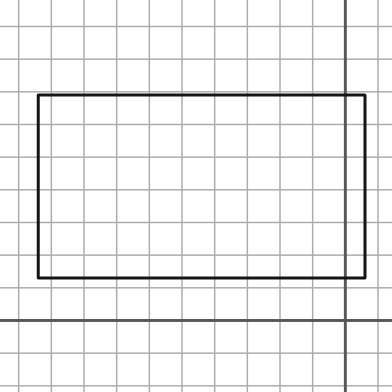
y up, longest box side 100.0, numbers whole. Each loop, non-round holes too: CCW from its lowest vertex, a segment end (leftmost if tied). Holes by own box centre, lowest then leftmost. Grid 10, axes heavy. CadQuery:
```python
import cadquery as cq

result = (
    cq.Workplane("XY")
    .moveTo(-94.0, 13.0)
    .lineTo(6.0, 13.0)
    .lineTo(6.0, 69.0)
    .lineTo(-94.0, 69.0)
    .close()
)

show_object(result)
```